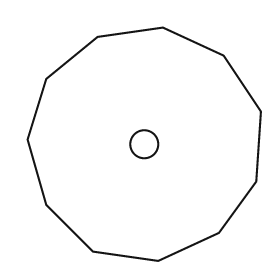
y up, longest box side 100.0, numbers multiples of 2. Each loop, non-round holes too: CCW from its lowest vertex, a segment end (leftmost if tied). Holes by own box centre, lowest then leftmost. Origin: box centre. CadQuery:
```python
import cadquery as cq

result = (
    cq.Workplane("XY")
    .moveTo(6.0, -50.0)
    .lineTo(32.0, -38.0)
    .lineTo(48.0, -16.0)
    .lineTo(50.0, 14.0)
    .lineTo(34.0, 38.0)
    .lineTo(8.0, 50.0)
    .lineTo(-20.0, 46.0)
    .lineTo(-42.0, 28.0)
    .lineTo(-50.0, 2.0)
    .lineTo(-42.0, -26.0)
    .lineTo(-22.0, -46.0)
    .close()
    .moveTo(0.0, 0.0)
    .circle(6.0)
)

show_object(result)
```